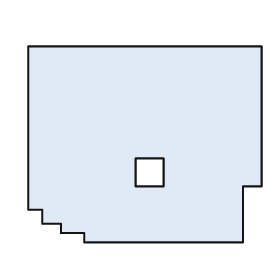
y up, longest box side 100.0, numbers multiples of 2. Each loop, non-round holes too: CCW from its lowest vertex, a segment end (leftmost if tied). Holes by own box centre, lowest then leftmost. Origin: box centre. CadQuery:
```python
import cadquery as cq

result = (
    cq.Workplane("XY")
    .moveTo(-26.0, -42.0)
    .lineTo(42.0, -42.0)
    .lineTo(42.0, -18.0)
    .lineTo(50.0, -18.0)
    .lineTo(50.0, 42.0)
    .lineTo(-50.0, 42.0)
    .lineTo(-50.0, -28.0)
    .lineTo(-44.0, -28.0)
    .lineTo(-44.0, -34.0)
    .lineTo(-36.0, -34.0)
    .lineTo(-36.0, -38.0)
    .lineTo(-26.0, -38.0)
    .close()
    .moveTo(-4.0, -18.0)
    .lineTo(8.0, -18.0)
    .lineTo(8.0, -6.0)
    .lineTo(-4.0, -6.0)
    .close()
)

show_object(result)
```